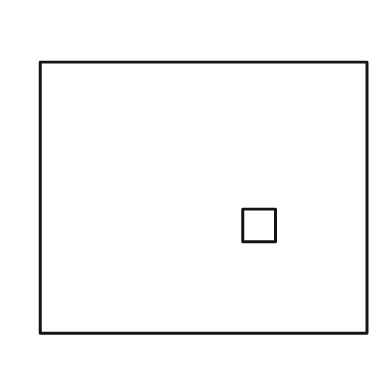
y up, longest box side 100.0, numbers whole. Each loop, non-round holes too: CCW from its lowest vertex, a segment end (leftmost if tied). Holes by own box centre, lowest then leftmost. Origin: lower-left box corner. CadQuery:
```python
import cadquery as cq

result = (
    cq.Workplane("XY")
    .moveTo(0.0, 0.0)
    .lineTo(100.0, 0.0)
    .lineTo(100.0, 83.0)
    .lineTo(0.0, 83.0)
    .close()
    .moveTo(62.0, 28.0)
    .lineTo(72.0, 28.0)
    .lineTo(72.0, 38.0)
    .lineTo(62.0, 38.0)
    .close()
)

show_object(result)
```